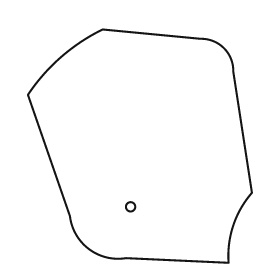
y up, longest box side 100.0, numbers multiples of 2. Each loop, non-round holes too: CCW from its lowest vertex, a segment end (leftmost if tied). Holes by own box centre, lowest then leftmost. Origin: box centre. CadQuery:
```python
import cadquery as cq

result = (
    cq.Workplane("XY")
    .moveTo(38.0, -50.0)
    .threePointArc((40.0, -34.0), (48.0, -20.0))
    .lineTo(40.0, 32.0)
    .threePointArc((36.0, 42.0), (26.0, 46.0))
    .lineTo(-16.0, 50.0)
    .threePointArc((-34.0, 38.0), (-48.0, 22.0))
    .lineTo(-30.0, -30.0)
    .threePointArc((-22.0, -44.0), (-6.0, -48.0))
    .close()
    .moveTo(-4.0, -26.0)
    .circle(2.0)
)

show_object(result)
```